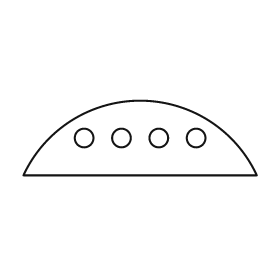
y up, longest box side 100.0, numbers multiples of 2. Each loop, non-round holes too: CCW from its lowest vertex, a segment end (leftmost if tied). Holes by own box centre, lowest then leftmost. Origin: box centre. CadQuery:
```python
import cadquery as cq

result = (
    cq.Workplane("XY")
    .moveTo(-50.0, -16.0)
    .lineTo(50.0, -16.0)
    .threePointArc((0.0, 16.0), (-50.0, -16.0))
    .close()
    .moveTo(-24.0, 0.0)
    .circle(4.0)
    .moveTo(-8.0, 0.0)
    .circle(4.0)
    .moveTo(8.0, 0.0)
    .circle(4.0)
    .moveTo(24.0, 0.0)
    .circle(4.0)
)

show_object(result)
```